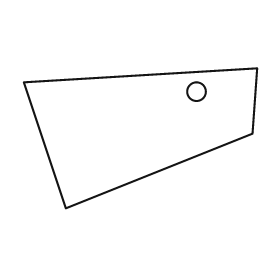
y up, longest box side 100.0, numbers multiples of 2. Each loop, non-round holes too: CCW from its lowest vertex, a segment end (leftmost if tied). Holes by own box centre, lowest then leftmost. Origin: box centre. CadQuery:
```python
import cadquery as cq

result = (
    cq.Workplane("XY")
    .moveTo(-32.0, -30.0)
    .lineTo(48.0, 2.0)
    .lineTo(50.0, 30.0)
    .lineTo(-50.0, 24.0)
    .close()
    .moveTo(24.0, 20.0)
    .circle(4.0)
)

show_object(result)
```